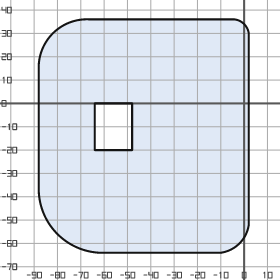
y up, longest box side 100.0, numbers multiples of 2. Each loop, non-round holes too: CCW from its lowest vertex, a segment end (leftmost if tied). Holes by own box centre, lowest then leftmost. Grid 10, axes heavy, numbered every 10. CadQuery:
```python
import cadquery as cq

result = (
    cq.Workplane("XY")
    .moveTo(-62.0, -64.0)
    .lineTo(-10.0, -64.0)
    .threePointArc((-2.0, -60.0), (2.0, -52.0))
    .lineTo(2.0, 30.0)
    .threePointArc((0.0, 34.0), (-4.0, 36.0))
    .lineTo(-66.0, 36.0)
    .threePointArc((-82.0, 30.0), (-88.0, 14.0))
    .lineTo(-88.0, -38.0)
    .threePointArc((-80.0, -56.0), (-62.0, -64.0))
    .close()
    .moveTo(-64.0, -20.0)
    .lineTo(-48.0, -20.0)
    .lineTo(-48.0, 0.0)
    .lineTo(-64.0, 0.0)
    .close()
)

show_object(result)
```